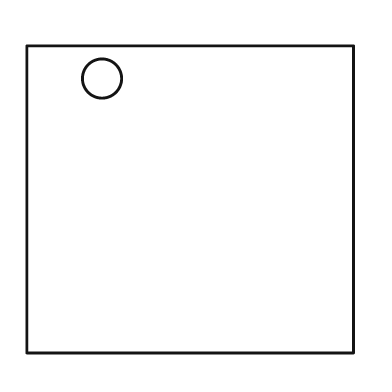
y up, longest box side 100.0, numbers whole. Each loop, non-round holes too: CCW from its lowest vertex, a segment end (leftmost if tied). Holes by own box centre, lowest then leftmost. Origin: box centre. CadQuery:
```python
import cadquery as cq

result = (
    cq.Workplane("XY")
    .moveTo(-50.0, -47.0)
    .lineTo(50.0, -47.0)
    .lineTo(50.0, 47.0)
    .lineTo(-50.0, 47.0)
    .close()
    .moveTo(-27.0, 37.0)
    .circle(6.0)
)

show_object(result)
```